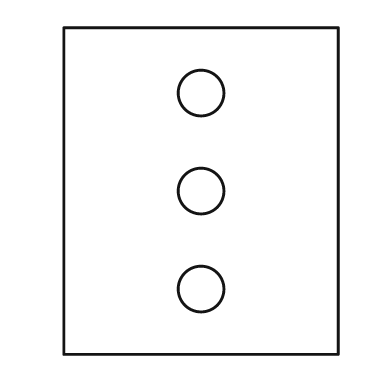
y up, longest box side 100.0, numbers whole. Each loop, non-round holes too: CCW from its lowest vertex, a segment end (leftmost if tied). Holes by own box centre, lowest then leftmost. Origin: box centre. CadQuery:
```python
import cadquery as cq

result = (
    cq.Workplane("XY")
    .moveTo(-42.0, -50.0)
    .lineTo(42.0, -50.0)
    .lineTo(42.0, 50.0)
    .lineTo(-42.0, 50.0)
    .close()
    .moveTo(0.0, -30.0)
    .circle(7.0)
    .moveTo(0.0, 0.0)
    .circle(7.0)
    .moveTo(0.0, 30.0)
    .circle(7.0)
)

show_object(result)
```